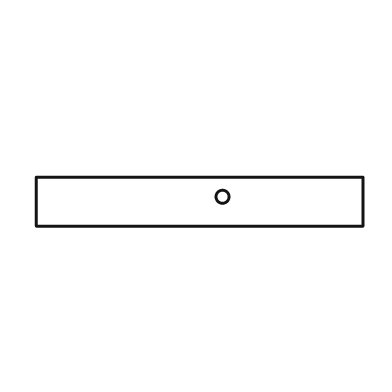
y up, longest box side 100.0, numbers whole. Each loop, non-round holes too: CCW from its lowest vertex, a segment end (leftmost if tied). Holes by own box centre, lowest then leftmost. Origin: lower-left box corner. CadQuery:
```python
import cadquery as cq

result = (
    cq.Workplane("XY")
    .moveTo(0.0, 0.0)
    .lineTo(100.0, 0.0)
    .lineTo(100.0, 15.0)
    .lineTo(0.0, 15.0)
    .close()
    .moveTo(57.0, 9.0)
    .circle(2.0)
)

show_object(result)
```